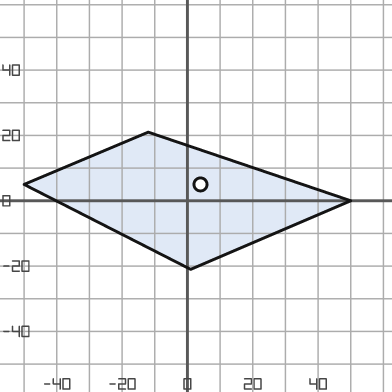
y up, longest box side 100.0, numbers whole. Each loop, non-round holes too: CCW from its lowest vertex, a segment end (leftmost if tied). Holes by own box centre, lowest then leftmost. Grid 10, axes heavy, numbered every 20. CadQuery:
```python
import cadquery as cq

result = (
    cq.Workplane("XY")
    .moveTo(1.0, -21.0)
    .lineTo(50.0, 0.0)
    .lineTo(-12.0, 21.0)
    .lineTo(-50.0, 5.0)
    .close()
    .moveTo(4.0, 5.0)
    .circle(2.0)
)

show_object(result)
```